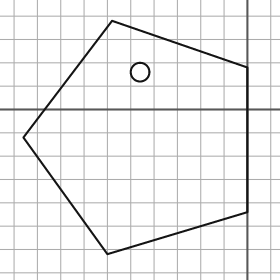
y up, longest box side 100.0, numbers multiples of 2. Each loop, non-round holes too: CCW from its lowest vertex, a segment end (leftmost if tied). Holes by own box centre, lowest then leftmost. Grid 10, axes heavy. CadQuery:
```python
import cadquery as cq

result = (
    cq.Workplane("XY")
    .moveTo(-60.0, -62.0)
    .lineTo(0.0, -44.0)
    .lineTo(0.0, 18.0)
    .lineTo(-58.0, 38.0)
    .lineTo(-96.0, -12.0)
    .close()
    .moveTo(-46.0, 16.0)
    .circle(4.0)
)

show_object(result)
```